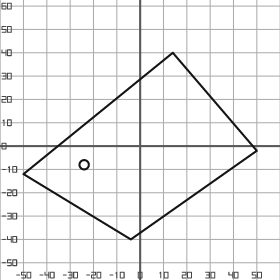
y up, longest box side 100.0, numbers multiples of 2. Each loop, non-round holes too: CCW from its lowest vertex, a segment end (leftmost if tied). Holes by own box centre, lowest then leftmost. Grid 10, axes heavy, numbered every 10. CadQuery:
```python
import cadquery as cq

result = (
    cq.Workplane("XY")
    .moveTo(-4.0, -40.0)
    .lineTo(50.0, -2.0)
    .lineTo(14.0, 40.0)
    .lineTo(-50.0, -12.0)
    .close()
    .moveTo(-24.0, -8.0)
    .circle(2.0)
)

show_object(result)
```